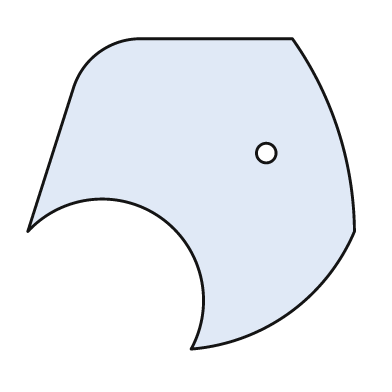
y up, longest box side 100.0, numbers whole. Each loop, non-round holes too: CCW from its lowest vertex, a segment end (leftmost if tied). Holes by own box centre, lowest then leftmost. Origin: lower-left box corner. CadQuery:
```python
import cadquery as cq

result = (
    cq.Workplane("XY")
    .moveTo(50.0, 0.0)
    .threePointArc((80.0, 11.0), (100.0, 36.0))
    .threePointArc((95.0, 67.0), (81.0, 95.0))
    .lineTo(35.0, 95.0)
    .threePointArc((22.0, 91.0), (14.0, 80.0))
    .lineTo(0.0, 36.0)
    .threePointArc((41.0, 40.0), (50.0, 0.0))
    .close()
    .moveTo(73.0, 60.0)
    .circle(3.0)
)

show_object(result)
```